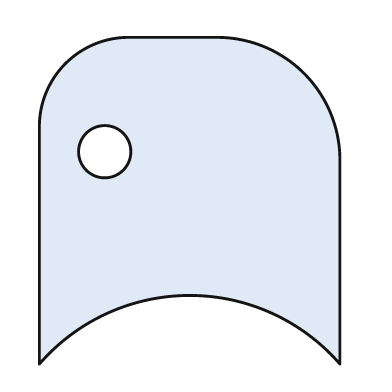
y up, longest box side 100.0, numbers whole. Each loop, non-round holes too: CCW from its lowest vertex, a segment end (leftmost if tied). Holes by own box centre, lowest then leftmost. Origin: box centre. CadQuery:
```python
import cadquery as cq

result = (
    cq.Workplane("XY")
    .moveTo(-46.0, -50.0)
    .threePointArc((0.0, -29.0), (46.0, -50.0))
    .lineTo(46.0, 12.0)
    .threePointArc((35.0, 39.0), (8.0, 50.0))
    .lineTo(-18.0, 50.0)
    .threePointArc((-38.0, 42.0), (-46.0, 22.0))
    .close()
    .moveTo(-26.0, 15.0)
    .circle(8.0)
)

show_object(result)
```